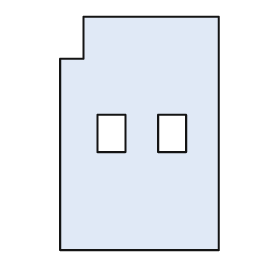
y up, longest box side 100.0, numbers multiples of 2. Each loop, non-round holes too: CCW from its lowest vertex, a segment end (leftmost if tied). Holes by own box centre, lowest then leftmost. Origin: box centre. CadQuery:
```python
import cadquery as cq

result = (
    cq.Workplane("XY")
    .moveTo(-34.0, -50.0)
    .lineTo(34.0, -50.0)
    .lineTo(34.0, 50.0)
    .lineTo(-24.0, 50.0)
    .lineTo(-24.0, 32.0)
    .lineTo(-34.0, 32.0)
    .close()
    .moveTo(-18.0, -8.0)
    .lineTo(-6.0, -8.0)
    .lineTo(-6.0, 8.0)
    .lineTo(-18.0, 8.0)
    .close()
    .moveTo(8.0, -8.0)
    .lineTo(20.0, -8.0)
    .lineTo(20.0, 8.0)
    .lineTo(8.0, 8.0)
    .close()
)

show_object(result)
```